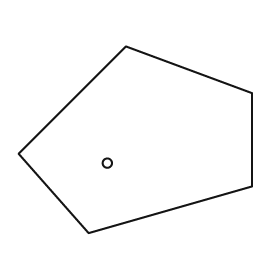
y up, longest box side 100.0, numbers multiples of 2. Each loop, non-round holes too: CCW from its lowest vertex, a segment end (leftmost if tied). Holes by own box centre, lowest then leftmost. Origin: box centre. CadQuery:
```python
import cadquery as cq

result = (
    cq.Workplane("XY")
    .moveTo(-20.0, -40.0)
    .lineTo(50.0, -20.0)
    .lineTo(50.0, 20.0)
    .lineTo(-4.0, 40.0)
    .lineTo(-50.0, -6.0)
    .close()
    .moveTo(-12.0, -10.0)
    .circle(2.0)
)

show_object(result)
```